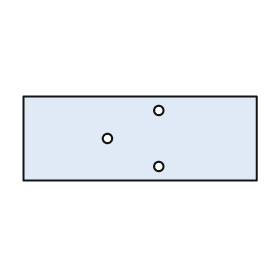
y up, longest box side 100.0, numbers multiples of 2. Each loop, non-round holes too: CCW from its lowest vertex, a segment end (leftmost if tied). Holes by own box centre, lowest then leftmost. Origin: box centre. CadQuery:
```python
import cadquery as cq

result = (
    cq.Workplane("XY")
    .moveTo(-50.0, -18.0)
    .lineTo(50.0, -18.0)
    .lineTo(50.0, 18.0)
    .lineTo(-50.0, 18.0)
    .close()
    .moveTo(8.0, -12.0)
    .circle(2.0)
    .moveTo(-14.0, 0.0)
    .circle(2.0)
    .moveTo(8.0, 12.0)
    .circle(2.0)
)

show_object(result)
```